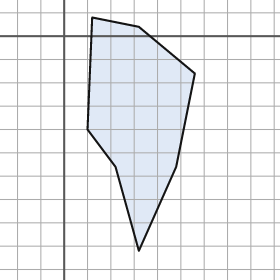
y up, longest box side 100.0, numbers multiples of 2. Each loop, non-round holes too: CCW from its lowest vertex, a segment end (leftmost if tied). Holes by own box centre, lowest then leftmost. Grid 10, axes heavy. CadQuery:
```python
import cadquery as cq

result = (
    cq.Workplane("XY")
    .moveTo(32.0, -92.0)
    .lineTo(48.0, -56.0)
    .lineTo(56.0, -16.0)
    .lineTo(32.0, 4.0)
    .lineTo(12.0, 8.0)
    .lineTo(10.0, -40.0)
    .lineTo(22.0, -56.0)
    .close()
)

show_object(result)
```